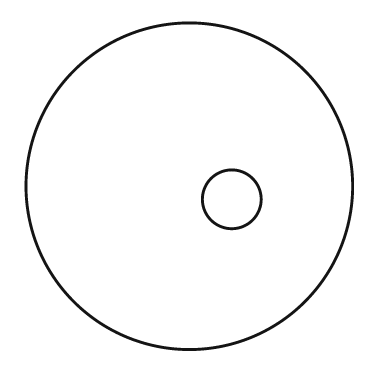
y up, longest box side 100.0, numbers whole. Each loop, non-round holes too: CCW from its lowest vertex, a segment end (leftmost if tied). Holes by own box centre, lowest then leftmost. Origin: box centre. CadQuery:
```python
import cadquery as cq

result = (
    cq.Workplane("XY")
    .moveTo(0.0, 0.0)
    .circle(50.0)
    .moveTo(13.0, -4.0)
    .circle(9.0)
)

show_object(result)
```